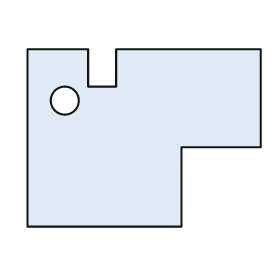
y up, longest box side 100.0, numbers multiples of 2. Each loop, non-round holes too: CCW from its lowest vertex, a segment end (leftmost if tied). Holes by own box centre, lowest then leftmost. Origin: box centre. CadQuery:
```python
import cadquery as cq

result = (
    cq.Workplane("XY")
    .moveTo(-50.0, -38.0)
    .lineTo(16.0, -38.0)
    .lineTo(16.0, -4.0)
    .lineTo(50.0, -4.0)
    .lineTo(50.0, 38.0)
    .lineTo(-12.0, 38.0)
    .lineTo(-12.0, 22.0)
    .lineTo(-24.0, 22.0)
    .lineTo(-24.0, 38.0)
    .lineTo(-50.0, 38.0)
    .close()
    .moveTo(-34.0, 16.0)
    .circle(6.0)
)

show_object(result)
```